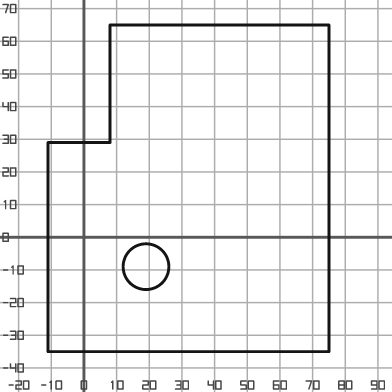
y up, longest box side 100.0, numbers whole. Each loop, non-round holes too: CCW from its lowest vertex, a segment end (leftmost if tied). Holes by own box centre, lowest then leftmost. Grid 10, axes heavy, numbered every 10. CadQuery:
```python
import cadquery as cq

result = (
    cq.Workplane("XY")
    .moveTo(-11.0, -35.0)
    .lineTo(75.0, -35.0)
    .lineTo(75.0, 65.0)
    .lineTo(8.0, 65.0)
    .lineTo(8.0, 29.0)
    .lineTo(-11.0, 29.0)
    .close()
    .moveTo(19.0, -9.0)
    .circle(7.0)
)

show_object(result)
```